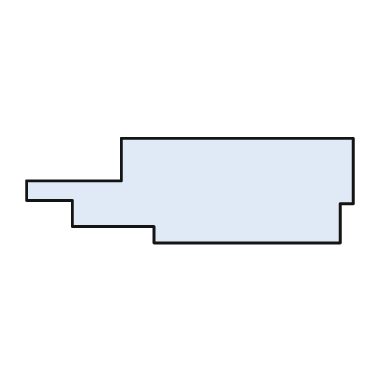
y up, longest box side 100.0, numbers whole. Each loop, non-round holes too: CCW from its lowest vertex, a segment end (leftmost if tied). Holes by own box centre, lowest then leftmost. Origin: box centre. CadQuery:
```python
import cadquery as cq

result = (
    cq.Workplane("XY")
    .moveTo(-11.0, -16.0)
    .lineTo(46.0, -16.0)
    .lineTo(46.0, -4.0)
    .lineTo(50.0, -4.0)
    .lineTo(50.0, 16.0)
    .lineTo(-21.0, 16.0)
    .lineTo(-21.0, 3.0)
    .lineTo(-50.0, 3.0)
    .lineTo(-50.0, -3.0)
    .lineTo(-36.0, -3.0)
    .lineTo(-36.0, -11.0)
    .lineTo(-11.0, -11.0)
    .close()
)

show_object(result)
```